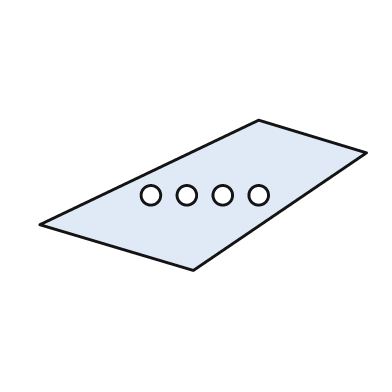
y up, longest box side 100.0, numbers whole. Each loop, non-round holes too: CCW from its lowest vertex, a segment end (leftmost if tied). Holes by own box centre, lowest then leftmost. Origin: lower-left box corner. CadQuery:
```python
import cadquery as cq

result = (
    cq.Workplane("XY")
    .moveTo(47.0, 0.0)
    .lineTo(100.0, 36.0)
    .lineTo(67.0, 46.0)
    .lineTo(0.0, 14.0)
    .close()
    .moveTo(34.0, 23.0)
    .circle(3.0)
    .moveTo(45.0, 23.0)
    .circle(3.0)
    .moveTo(56.0, 23.0)
    .circle(3.0)
    .moveTo(67.0, 23.0)
    .circle(3.0)
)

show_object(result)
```